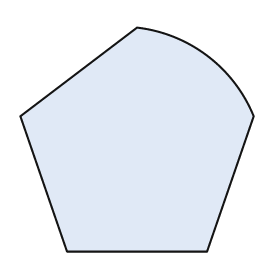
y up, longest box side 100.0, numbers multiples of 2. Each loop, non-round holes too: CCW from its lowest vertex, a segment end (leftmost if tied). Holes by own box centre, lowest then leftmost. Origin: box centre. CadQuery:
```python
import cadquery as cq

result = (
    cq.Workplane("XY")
    .moveTo(-30.0, -48.0)
    .lineTo(30.0, -48.0)
    .lineTo(50.0, 10.0)
    .threePointArc((30.0, 36.0), (0.0, 48.0))
    .lineTo(-50.0, 10.0)
    .close()
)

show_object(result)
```